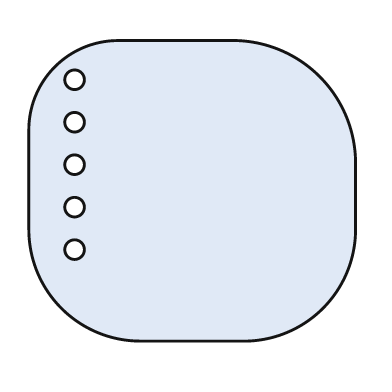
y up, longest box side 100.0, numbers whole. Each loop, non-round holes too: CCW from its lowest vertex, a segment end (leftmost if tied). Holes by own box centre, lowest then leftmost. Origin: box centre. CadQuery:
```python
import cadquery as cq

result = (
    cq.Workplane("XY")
    .moveTo(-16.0, -46.0)
    .lineTo(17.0, -46.0)
    .threePointArc((40.0, -36.0), (50.0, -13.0))
    .lineTo(50.0, 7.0)
    .threePointArc((39.0, 35.0), (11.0, 46.0))
    .lineTo(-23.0, 46.0)
    .threePointArc((-42.0, 38.0), (-50.0, 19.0))
    .lineTo(-50.0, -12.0)
    .threePointArc((-40.0, -36.0), (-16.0, -46.0))
    .close()
    .moveTo(-36.0, -18.0)
    .circle(3.0)
    .moveTo(-36.0, -5.0)
    .circle(3.0)
    .moveTo(-36.0, 8.0)
    .circle(3.0)
    .moveTo(-36.0, 21.0)
    .circle(3.0)
    .moveTo(-36.0, 34.0)
    .circle(3.0)
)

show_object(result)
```